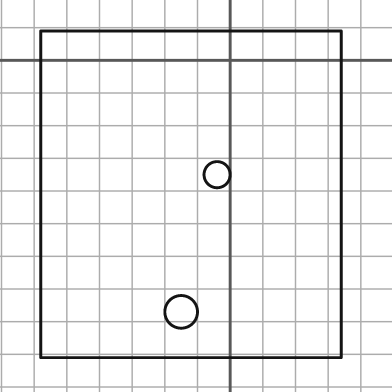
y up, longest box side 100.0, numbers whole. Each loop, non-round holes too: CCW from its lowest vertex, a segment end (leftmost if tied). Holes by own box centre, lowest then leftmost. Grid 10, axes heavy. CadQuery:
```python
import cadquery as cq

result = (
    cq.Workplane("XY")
    .moveTo(-58.0, -91.0)
    .lineTo(34.0, -91.0)
    .lineTo(34.0, 9.0)
    .lineTo(-58.0, 9.0)
    .close()
    .moveTo(-15.0, -77.0)
    .circle(5.0)
    .moveTo(-4.0, -35.0)
    .circle(4.0)
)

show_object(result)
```